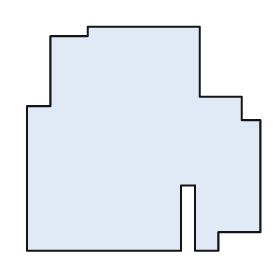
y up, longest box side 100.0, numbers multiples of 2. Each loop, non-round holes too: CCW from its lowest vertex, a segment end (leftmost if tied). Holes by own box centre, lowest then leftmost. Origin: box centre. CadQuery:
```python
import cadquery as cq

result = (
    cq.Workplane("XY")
    .moveTo(-50.0, -48.0)
    .lineTo(16.0, -48.0)
    .lineTo(16.0, -20.0)
    .lineTo(22.0, -20.0)
    .lineTo(22.0, -48.0)
    .lineTo(32.0, -48.0)
    .lineTo(32.0, -40.0)
    .lineTo(50.0, -40.0)
    .lineTo(50.0, 8.0)
    .lineTo(42.0, 8.0)
    .lineTo(42.0, 18.0)
    .lineTo(24.0, 18.0)
    .lineTo(24.0, 48.0)
    .lineTo(-24.0, 48.0)
    .lineTo(-24.0, 44.0)
    .lineTo(-40.0, 44.0)
    .lineTo(-40.0, 14.0)
    .lineTo(-50.0, 14.0)
    .close()
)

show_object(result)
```